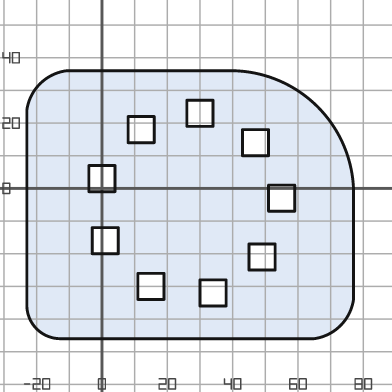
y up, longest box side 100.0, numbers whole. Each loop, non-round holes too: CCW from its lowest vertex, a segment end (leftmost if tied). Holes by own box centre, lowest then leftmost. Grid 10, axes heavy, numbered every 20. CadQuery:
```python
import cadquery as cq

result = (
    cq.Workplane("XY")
    .moveTo(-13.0, -46.0)
    .lineTo(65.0, -46.0)
    .threePointArc((73.0, -42.0), (77.0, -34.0))
    .lineTo(77.0, 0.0)
    .threePointArc((66.0, 25.0), (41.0, 36.0))
    .lineTo(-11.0, 36.0)
    .threePointArc((-19.0, 32.0), (-23.0, 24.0))
    .lineTo(-23.0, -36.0)
    .threePointArc((-20.0, -43.0), (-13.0, -46.0))
    .close()
    .moveTo(30.0, -36.0)
    .lineTo(38.0, -36.0)
    .lineTo(38.0, -28.0)
    .lineTo(30.0, -28.0)
    .close()
    .moveTo(11.0, -34.0)
    .lineTo(19.0, -34.0)
    .lineTo(19.0, -26.0)
    .lineTo(11.0, -26.0)
    .close()
    .moveTo(45.0, -25.0)
    .lineTo(53.0, -25.0)
    .lineTo(53.0, -17.0)
    .lineTo(45.0, -17.0)
    .close()
    .moveTo(-3.0, -20.0)
    .lineTo(5.0, -20.0)
    .lineTo(5.0, -12.0)
    .lineTo(-3.0, -12.0)
    .close()
    .moveTo(51.0, -7.0)
    .lineTo(59.0, -7.0)
    .lineTo(59.0, 1.0)
    .lineTo(51.0, 1.0)
    .close()
    .moveTo(-4.0, -1.0)
    .lineTo(4.0, -1.0)
    .lineTo(4.0, 7.0)
    .lineTo(-4.0, 7.0)
    .close()
    .moveTo(43.0, 10.0)
    .lineTo(51.0, 10.0)
    .lineTo(51.0, 18.0)
    .lineTo(43.0, 18.0)
    .close()
    .moveTo(8.0, 14.0)
    .lineTo(16.0, 14.0)
    .lineTo(16.0, 22.0)
    .lineTo(8.0, 22.0)
    .close()
    .moveTo(26.0, 19.0)
    .lineTo(34.0, 19.0)
    .lineTo(34.0, 27.0)
    .lineTo(26.0, 27.0)
    .close()
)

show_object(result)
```